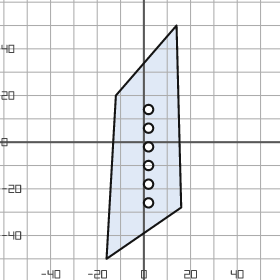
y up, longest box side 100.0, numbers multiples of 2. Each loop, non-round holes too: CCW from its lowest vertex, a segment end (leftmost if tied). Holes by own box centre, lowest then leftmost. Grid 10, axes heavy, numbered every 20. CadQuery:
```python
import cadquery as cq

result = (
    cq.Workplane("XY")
    .moveTo(-16.0, -50.0)
    .lineTo(16.0, -28.0)
    .lineTo(14.0, 50.0)
    .lineTo(-12.0, 20.0)
    .close()
    .moveTo(2.0, -26.0)
    .circle(2.0)
    .moveTo(2.0, -18.0)
    .circle(2.0)
    .moveTo(2.0, -10.0)
    .circle(2.0)
    .moveTo(2.0, -2.0)
    .circle(2.0)
    .moveTo(2.0, 6.0)
    .circle(2.0)
    .moveTo(2.0, 14.0)
    .circle(2.0)
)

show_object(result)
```